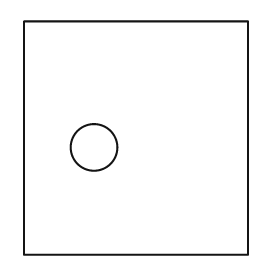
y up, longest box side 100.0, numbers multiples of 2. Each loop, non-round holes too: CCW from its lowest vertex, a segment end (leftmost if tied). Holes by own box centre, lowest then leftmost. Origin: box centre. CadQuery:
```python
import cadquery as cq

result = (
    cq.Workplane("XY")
    .moveTo(-48.0, -50.0)
    .lineTo(48.0, -50.0)
    .lineTo(48.0, 50.0)
    .lineTo(-48.0, 50.0)
    .close()
    .moveTo(-18.0, -4.0)
    .circle(10.0)
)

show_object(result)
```